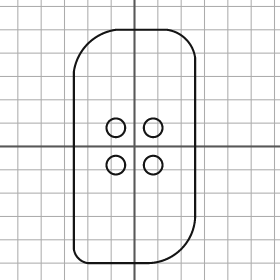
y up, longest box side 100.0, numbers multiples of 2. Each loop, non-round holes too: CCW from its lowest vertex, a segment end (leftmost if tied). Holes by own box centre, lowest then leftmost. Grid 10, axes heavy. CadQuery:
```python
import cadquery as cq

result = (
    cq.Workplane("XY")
    .moveTo(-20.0, -50.0)
    .lineTo(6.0, -50.0)
    .threePointArc((20.0, -44.0), (26.0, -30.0))
    .lineTo(26.0, 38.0)
    .threePointArc((22.0, 46.0), (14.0, 50.0))
    .lineTo(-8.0, 50.0)
    .threePointArc((-20.0, 44.0), (-26.0, 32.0))
    .lineTo(-26.0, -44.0)
    .threePointArc((-24.0, -48.0), (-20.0, -50.0))
    .close()
    .moveTo(-8.0, -8.0)
    .circle(4.0)
    .moveTo(8.0, -8.0)
    .circle(4.0)
    .moveTo(-8.0, 8.0)
    .circle(4.0)
    .moveTo(8.0, 8.0)
    .circle(4.0)
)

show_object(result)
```